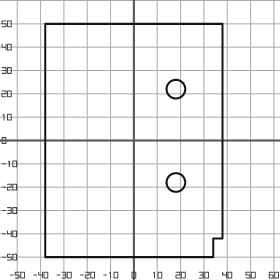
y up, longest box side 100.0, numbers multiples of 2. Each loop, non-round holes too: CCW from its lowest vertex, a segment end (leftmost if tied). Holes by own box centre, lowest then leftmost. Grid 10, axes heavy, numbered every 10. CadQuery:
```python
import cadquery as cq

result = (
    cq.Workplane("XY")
    .moveTo(-38.0, -50.0)
    .lineTo(34.0, -50.0)
    .lineTo(34.0, -42.0)
    .lineTo(38.0, -42.0)
    .lineTo(38.0, 50.0)
    .lineTo(-38.0, 50.0)
    .close()
    .moveTo(18.0, -18.0)
    .circle(4.0)
    .moveTo(18.0, 22.0)
    .circle(4.0)
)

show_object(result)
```